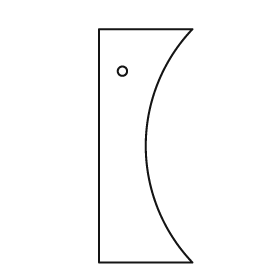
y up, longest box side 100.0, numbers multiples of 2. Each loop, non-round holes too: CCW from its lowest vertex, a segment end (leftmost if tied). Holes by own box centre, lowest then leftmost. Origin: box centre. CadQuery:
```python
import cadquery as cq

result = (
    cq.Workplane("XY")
    .moveTo(-20.0, -50.0)
    .lineTo(20.0, -50.0)
    .threePointArc((0.0, 0.0), (20.0, 50.0))
    .lineTo(-20.0, 50.0)
    .close()
    .moveTo(-10.0, 32.0)
    .circle(2.0)
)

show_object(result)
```